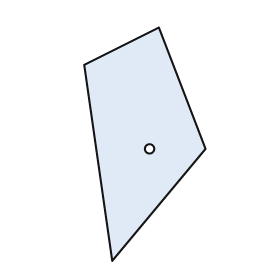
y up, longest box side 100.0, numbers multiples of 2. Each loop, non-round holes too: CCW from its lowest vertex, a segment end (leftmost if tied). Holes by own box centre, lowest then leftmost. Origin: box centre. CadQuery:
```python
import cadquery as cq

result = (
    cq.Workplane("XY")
    .moveTo(-14.0, -50.0)
    .lineTo(26.0, -2.0)
    .lineTo(6.0, 50.0)
    .lineTo(-26.0, 34.0)
    .close()
    .moveTo(2.0, -2.0)
    .circle(2.0)
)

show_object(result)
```